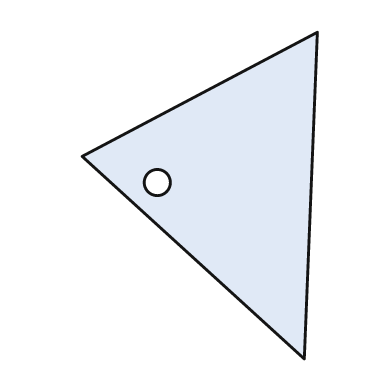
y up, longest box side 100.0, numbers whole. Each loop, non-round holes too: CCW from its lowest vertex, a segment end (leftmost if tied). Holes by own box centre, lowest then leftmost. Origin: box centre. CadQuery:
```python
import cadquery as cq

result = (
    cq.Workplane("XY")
    .moveTo(32.0, -50.0)
    .lineTo(36.0, 50.0)
    .lineTo(-36.0, 12.0)
    .close()
    .moveTo(-13.0, 4.0)
    .circle(4.0)
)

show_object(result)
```